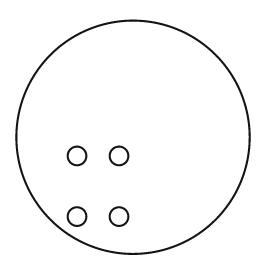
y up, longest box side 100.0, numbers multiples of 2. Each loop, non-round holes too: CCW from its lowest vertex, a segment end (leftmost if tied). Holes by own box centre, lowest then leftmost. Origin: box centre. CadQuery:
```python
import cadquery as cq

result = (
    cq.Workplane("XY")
    .moveTo(0.0, 0.0)
    .circle(50.0)
    .moveTo(-24.0, -34.0)
    .circle(4.0)
    .moveTo(-6.0, -34.0)
    .circle(4.0)
    .moveTo(-24.0, -8.0)
    .circle(4.0)
    .moveTo(-6.0, -8.0)
    .circle(4.0)
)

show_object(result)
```